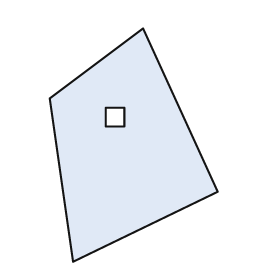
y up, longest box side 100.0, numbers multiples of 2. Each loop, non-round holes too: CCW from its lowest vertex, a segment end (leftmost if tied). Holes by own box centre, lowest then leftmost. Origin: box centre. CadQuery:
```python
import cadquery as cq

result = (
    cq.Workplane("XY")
    .moveTo(-26.0, -50.0)
    .lineTo(36.0, -20.0)
    .lineTo(4.0, 50.0)
    .lineTo(-36.0, 20.0)
    .close()
    .moveTo(-12.0, 8.0)
    .lineTo(-4.0, 8.0)
    .lineTo(-4.0, 16.0)
    .lineTo(-12.0, 16.0)
    .close()
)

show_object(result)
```